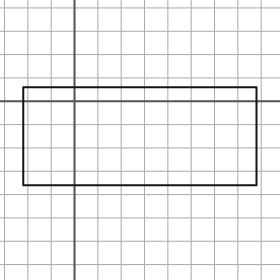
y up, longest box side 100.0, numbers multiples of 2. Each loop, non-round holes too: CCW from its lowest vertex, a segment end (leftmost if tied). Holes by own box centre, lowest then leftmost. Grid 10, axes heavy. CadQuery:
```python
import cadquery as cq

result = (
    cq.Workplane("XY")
    .moveTo(-22.0, -36.0)
    .lineTo(78.0, -36.0)
    .lineTo(78.0, 6.0)
    .lineTo(-22.0, 6.0)
    .close()
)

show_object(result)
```